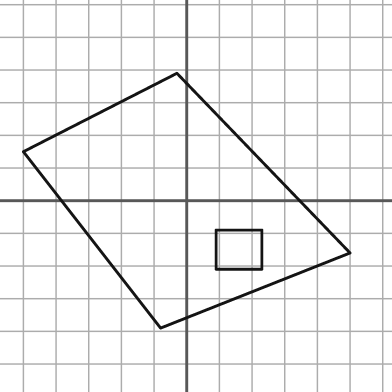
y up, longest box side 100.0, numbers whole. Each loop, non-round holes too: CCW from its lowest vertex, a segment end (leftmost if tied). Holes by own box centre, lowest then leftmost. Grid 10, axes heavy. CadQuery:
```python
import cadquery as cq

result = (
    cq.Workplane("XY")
    .moveTo(-8.0, -39.0)
    .lineTo(50.0, -16.0)
    .lineTo(-3.0, 39.0)
    .lineTo(-50.0, 15.0)
    .close()
    .moveTo(9.0, -21.0)
    .lineTo(23.0, -21.0)
    .lineTo(23.0, -9.0)
    .lineTo(9.0, -9.0)
    .close()
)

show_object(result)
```